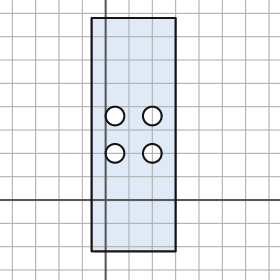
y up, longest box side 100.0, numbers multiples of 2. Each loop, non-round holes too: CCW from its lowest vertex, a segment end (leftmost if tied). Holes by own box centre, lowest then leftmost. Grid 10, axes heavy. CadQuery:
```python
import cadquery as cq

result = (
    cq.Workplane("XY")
    .moveTo(-6.0, -22.0)
    .lineTo(30.0, -22.0)
    .lineTo(30.0, 78.0)
    .lineTo(-6.0, 78.0)
    .close()
    .moveTo(4.0, 20.0)
    .circle(4.0)
    .moveTo(20.0, 20.0)
    .circle(4.0)
    .moveTo(4.0, 36.0)
    .circle(4.0)
    .moveTo(20.0, 36.0)
    .circle(4.0)
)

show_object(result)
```